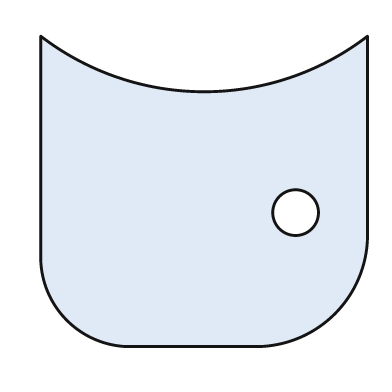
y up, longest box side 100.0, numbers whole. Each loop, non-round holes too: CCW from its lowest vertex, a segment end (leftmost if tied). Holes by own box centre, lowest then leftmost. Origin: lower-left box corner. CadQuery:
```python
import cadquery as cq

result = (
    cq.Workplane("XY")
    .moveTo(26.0, 0.0)
    .lineTo(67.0, 0.0)
    .threePointArc((90.0, 10.0), (100.0, 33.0))
    .lineTo(100.0, 95.0)
    .threePointArc((50.0, 78.0), (0.0, 95.0))
    .lineTo(0.0, 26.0)
    .threePointArc((8.0, 8.0), (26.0, 0.0))
    .close()
    .moveTo(78.0, 41.0)
    .circle(7.0)
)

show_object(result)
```